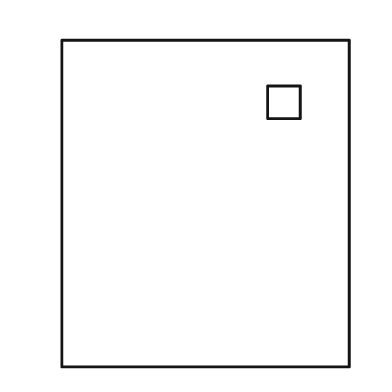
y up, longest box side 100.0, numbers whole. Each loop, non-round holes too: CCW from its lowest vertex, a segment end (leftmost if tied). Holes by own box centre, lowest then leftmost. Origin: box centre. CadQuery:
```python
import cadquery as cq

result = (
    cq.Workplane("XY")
    .moveTo(-44.0, -50.0)
    .lineTo(44.0, -50.0)
    .lineTo(44.0, 50.0)
    .lineTo(-44.0, 50.0)
    .close()
    .moveTo(19.0, 26.0)
    .lineTo(29.0, 26.0)
    .lineTo(29.0, 36.0)
    .lineTo(19.0, 36.0)
    .close()
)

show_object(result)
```